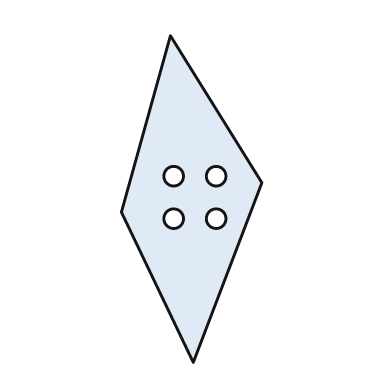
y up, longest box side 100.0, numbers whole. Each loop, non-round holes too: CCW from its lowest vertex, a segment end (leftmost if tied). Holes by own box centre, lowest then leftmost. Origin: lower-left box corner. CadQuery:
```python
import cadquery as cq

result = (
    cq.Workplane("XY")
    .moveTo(22.0, 0.0)
    .lineTo(43.0, 55.0)
    .lineTo(15.0, 100.0)
    .lineTo(0.0, 46.0)
    .close()
    .moveTo(16.0, 44.0)
    .circle(3.0)
    .moveTo(29.0, 44.0)
    .circle(3.0)
    .moveTo(16.0, 57.0)
    .circle(3.0)
    .moveTo(29.0, 57.0)
    .circle(3.0)
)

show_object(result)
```